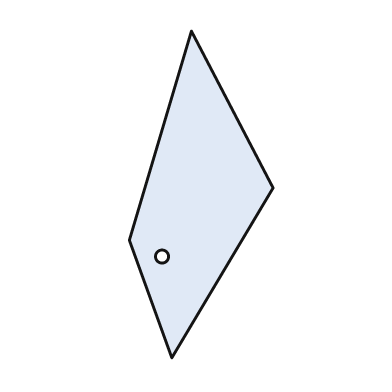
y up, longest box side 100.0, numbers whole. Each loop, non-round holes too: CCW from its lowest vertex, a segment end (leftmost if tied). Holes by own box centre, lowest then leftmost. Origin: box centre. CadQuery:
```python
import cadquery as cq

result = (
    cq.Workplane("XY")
    .moveTo(-9.0, -50.0)
    .lineTo(22.0, 2.0)
    .lineTo(-3.0, 50.0)
    .lineTo(-22.0, -14.0)
    .close()
    .moveTo(-12.0, -19.0)
    .circle(2.0)
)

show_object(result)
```